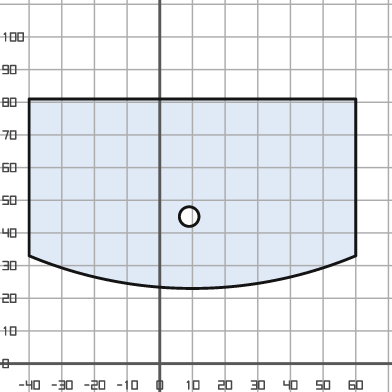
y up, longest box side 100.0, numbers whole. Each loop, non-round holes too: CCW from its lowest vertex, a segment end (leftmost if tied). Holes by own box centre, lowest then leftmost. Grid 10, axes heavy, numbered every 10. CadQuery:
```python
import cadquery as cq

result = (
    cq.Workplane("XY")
    .moveTo(-40.0, 33.0)
    .threePointArc((10.0, 23.0), (60.0, 33.0))
    .lineTo(60.0, 81.0)
    .lineTo(-40.0, 81.0)
    .close()
    .moveTo(9.0, 45.0)
    .circle(3.0)
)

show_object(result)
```